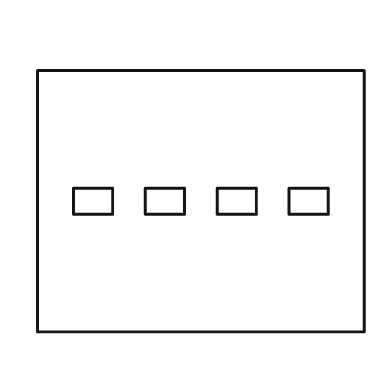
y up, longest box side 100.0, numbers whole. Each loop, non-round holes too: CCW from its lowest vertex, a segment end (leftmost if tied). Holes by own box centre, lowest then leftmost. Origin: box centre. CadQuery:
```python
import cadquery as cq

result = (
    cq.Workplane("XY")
    .moveTo(-50.0, -40.0)
    .lineTo(50.0, -40.0)
    .lineTo(50.0, 40.0)
    .lineTo(-50.0, 40.0)
    .close()
    .moveTo(-39.0, -4.0)
    .lineTo(-27.0, -4.0)
    .lineTo(-27.0, 4.0)
    .lineTo(-39.0, 4.0)
    .close()
    .moveTo(-17.0, -4.0)
    .lineTo(-5.0, -4.0)
    .lineTo(-5.0, 4.0)
    .lineTo(-17.0, 4.0)
    .close()
    .moveTo(5.0, -4.0)
    .lineTo(17.0, -4.0)
    .lineTo(17.0, 4.0)
    .lineTo(5.0, 4.0)
    .close()
    .moveTo(27.0, -4.0)
    .lineTo(39.0, -4.0)
    .lineTo(39.0, 4.0)
    .lineTo(27.0, 4.0)
    .close()
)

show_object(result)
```